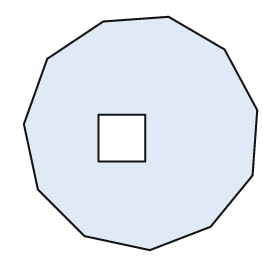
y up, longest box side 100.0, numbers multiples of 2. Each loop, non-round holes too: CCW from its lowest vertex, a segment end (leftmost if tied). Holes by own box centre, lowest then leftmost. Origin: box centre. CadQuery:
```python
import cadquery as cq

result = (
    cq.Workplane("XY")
    .moveTo(4.0, -50.0)
    .lineTo(30.0, -40.0)
    .lineTo(48.0, -18.0)
    .lineTo(50.0, 10.0)
    .lineTo(36.0, 36.0)
    .lineTo(12.0, 50.0)
    .lineTo(-16.0, 48.0)
    .lineTo(-40.0, 32.0)
    .lineTo(-50.0, 4.0)
    .lineTo(-44.0, -24.0)
    .lineTo(-24.0, -44.0)
    .close()
    .moveTo(-18.0, -12.0)
    .lineTo(2.0, -12.0)
    .lineTo(2.0, 8.0)
    .lineTo(-18.0, 8.0)
    .close()
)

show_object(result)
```